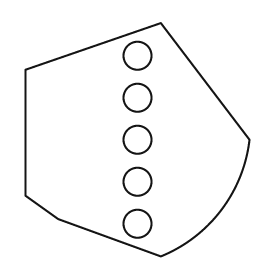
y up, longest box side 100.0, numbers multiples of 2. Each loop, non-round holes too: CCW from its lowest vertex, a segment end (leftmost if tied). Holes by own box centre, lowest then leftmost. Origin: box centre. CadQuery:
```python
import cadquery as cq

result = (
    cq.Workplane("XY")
    .moveTo(10.0, -50.0)
    .threePointArc((36.0, -30.0), (48.0, 0.0))
    .lineTo(10.0, 50.0)
    .lineTo(-48.0, 30.0)
    .lineTo(-48.0, -24.0)
    .lineTo(-34.0, -34.0)
    .close()
    .moveTo(0.0, -36.0)
    .circle(6.0)
    .moveTo(0.0, -18.0)
    .circle(6.0)
    .moveTo(0.0, 0.0)
    .circle(6.0)
    .moveTo(0.0, 18.0)
    .circle(6.0)
    .moveTo(0.0, 36.0)
    .circle(6.0)
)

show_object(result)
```